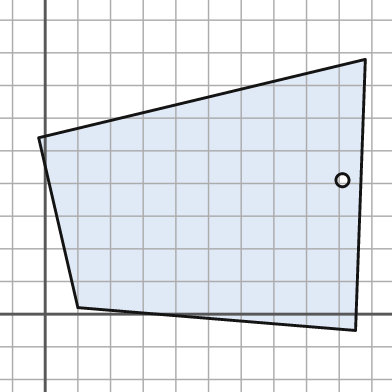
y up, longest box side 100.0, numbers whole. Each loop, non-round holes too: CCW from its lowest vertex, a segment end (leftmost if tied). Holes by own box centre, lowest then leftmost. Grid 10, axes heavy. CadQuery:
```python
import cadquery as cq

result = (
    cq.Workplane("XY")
    .moveTo(95.0, -5.0)
    .lineTo(98.0, 78.0)
    .lineTo(-2.0, 54.0)
    .lineTo(10.0, 2.0)
    .close()
    .moveTo(91.0, 41.0)
    .circle(2.0)
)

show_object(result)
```